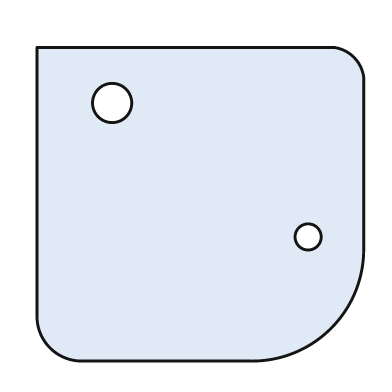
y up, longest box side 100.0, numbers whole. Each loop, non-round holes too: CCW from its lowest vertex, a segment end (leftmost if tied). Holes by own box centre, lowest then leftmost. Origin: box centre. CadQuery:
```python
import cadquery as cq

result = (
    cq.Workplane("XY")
    .moveTo(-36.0, -48.0)
    .lineTo(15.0, -48.0)
    .threePointArc((40.0, -38.0), (50.0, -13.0))
    .lineTo(50.0, 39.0)
    .threePointArc((47.0, 45.0), (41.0, 48.0))
    .lineTo(-50.0, 48.0)
    .lineTo(-50.0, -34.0)
    .threePointArc((-46.0, -44.0), (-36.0, -48.0))
    .close()
    .moveTo(33.0, -10.0)
    .circle(4.0)
    .moveTo(-27.0, 31.0)
    .circle(6.0)
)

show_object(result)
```